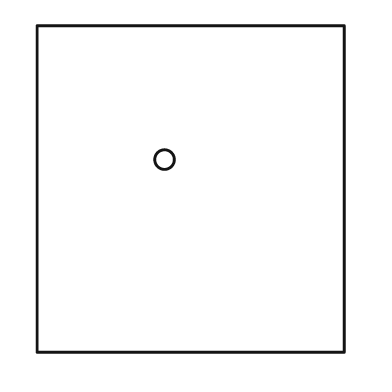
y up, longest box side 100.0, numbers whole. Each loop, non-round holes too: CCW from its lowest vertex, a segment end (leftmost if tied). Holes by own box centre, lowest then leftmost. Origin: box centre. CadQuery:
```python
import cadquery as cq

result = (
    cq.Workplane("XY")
    .moveTo(-47.0, -50.0)
    .lineTo(47.0, -50.0)
    .lineTo(47.0, 50.0)
    .lineTo(-47.0, 50.0)
    .close()
    .moveTo(-8.0, 9.0)
    .circle(3.0)
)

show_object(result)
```